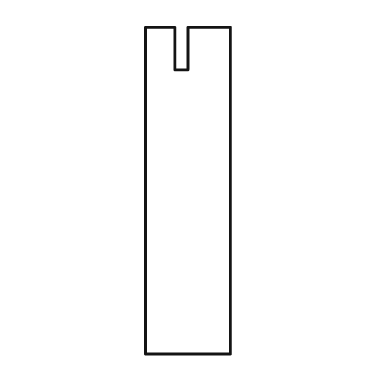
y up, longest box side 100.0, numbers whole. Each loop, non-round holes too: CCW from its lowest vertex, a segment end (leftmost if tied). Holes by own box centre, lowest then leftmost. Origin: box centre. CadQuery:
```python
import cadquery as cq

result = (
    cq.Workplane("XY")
    .moveTo(-13.0, -50.0)
    .lineTo(13.0, -50.0)
    .lineTo(13.0, 50.0)
    .lineTo(0.0, 50.0)
    .lineTo(0.0, 37.0)
    .lineTo(-4.0, 37.0)
    .lineTo(-4.0, 50.0)
    .lineTo(-13.0, 50.0)
    .close()
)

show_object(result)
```